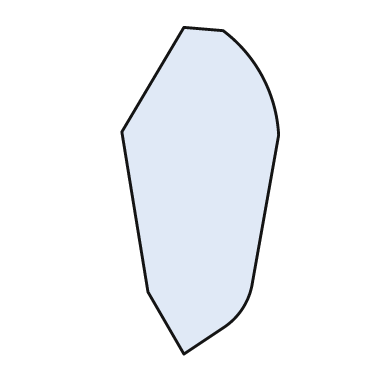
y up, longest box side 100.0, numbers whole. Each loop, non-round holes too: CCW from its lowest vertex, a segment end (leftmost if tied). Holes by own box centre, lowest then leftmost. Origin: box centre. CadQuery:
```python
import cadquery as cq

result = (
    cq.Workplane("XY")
    .moveTo(-5.0, -50.0)
    .lineTo(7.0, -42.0)
    .threePointArc((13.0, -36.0), (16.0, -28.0))
    .lineTo(24.0, 17.0)
    .threePointArc((19.0, 35.0), (7.0, 49.0))
    .lineTo(-5.0, 50.0)
    .lineTo(-24.0, 18.0)
    .lineTo(-16.0, -31.0)
    .close()
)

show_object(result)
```